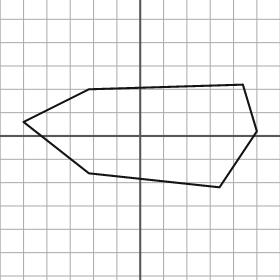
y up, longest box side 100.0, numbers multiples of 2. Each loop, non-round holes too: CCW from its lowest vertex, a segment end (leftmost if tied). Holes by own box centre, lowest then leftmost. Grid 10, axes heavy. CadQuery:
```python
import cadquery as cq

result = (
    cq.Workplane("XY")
    .moveTo(34.0, -22.0)
    .lineTo(50.0, 2.0)
    .lineTo(44.0, 22.0)
    .lineTo(-22.0, 20.0)
    .lineTo(-50.0, 6.0)
    .lineTo(-22.0, -16.0)
    .close()
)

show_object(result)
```